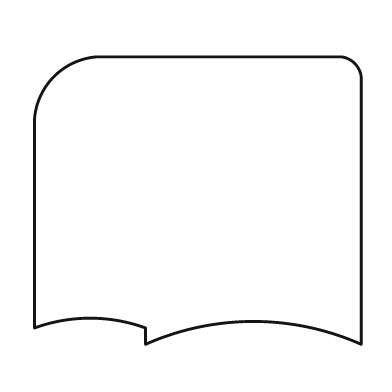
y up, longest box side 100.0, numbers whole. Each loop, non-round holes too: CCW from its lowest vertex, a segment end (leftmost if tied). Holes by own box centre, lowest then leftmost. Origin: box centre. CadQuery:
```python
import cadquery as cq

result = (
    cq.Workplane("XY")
    .moveTo(-16.0, -44.0)
    .threePointArc((17.0, -37.0), (50.0, -44.0))
    .lineTo(50.0, 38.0)
    .threePointArc((48.0, 42.0), (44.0, 44.0))
    .lineTo(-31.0, 44.0)
    .threePointArc((-44.0, 38.0), (-50.0, 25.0))
    .lineTo(-50.0, -39.0)
    .threePointArc((-33.0, -36.0), (-16.0, -39.0))
    .close()
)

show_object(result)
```